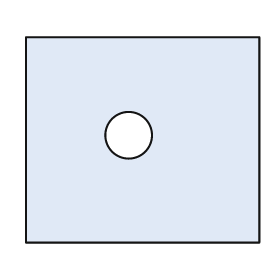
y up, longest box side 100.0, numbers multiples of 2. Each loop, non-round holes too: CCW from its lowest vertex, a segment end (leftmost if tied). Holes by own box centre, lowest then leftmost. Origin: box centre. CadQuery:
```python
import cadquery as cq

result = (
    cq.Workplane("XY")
    .moveTo(-50.0, -44.0)
    .lineTo(50.0, -44.0)
    .lineTo(50.0, 44.0)
    .lineTo(-50.0, 44.0)
    .close()
    .moveTo(-6.0, 2.0)
    .circle(10.0)
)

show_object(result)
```